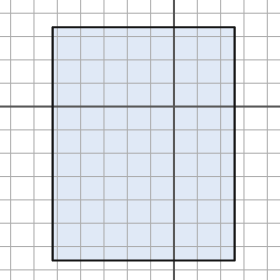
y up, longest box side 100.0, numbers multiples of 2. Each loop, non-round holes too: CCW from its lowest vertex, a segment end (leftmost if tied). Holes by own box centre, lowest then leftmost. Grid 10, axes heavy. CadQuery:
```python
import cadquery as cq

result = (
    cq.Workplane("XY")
    .moveTo(-52.0, -66.0)
    .lineTo(26.0, -66.0)
    .lineTo(26.0, 34.0)
    .lineTo(-52.0, 34.0)
    .close()
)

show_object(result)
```